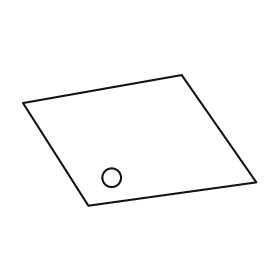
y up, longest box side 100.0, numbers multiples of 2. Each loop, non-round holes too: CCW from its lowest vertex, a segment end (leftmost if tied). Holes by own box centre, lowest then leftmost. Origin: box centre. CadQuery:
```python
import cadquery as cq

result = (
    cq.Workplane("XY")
    .moveTo(-22.0, -28.0)
    .lineTo(50.0, -18.0)
    .lineTo(18.0, 28.0)
    .lineTo(-50.0, 16.0)
    .close()
    .moveTo(-12.0, -16.0)
    .circle(4.0)
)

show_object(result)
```